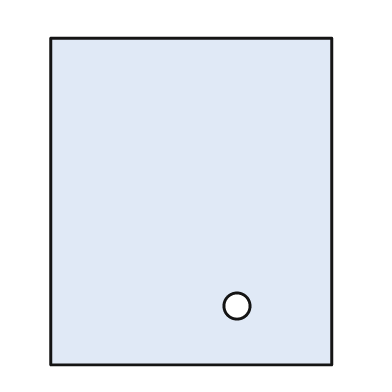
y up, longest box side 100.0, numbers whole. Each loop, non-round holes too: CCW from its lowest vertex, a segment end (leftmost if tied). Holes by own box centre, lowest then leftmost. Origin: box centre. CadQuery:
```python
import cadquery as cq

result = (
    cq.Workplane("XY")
    .moveTo(-43.0, -50.0)
    .lineTo(43.0, -50.0)
    .lineTo(43.0, 50.0)
    .lineTo(-43.0, 50.0)
    .close()
    .moveTo(14.0, -32.0)
    .circle(4.0)
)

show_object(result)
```